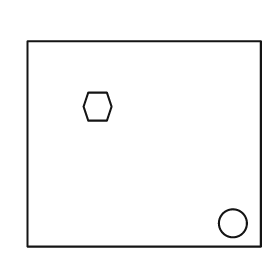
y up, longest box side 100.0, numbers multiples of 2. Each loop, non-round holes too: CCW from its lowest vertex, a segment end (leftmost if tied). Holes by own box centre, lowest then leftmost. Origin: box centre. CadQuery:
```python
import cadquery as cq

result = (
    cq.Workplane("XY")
    .moveTo(-50.0, -44.0)
    .lineTo(50.0, -44.0)
    .lineTo(50.0, 44.0)
    .lineTo(-50.0, 44.0)
    .close()
    .moveTo(38.0, -34.0)
    .circle(6.0)
    .moveTo(-24.0, 10.0)
    .lineTo(-16.0, 10.0)
    .lineTo(-14.0, 16.0)
    .lineTo(-16.0, 22.0)
    .lineTo(-24.0, 22.0)
    .lineTo(-26.0, 16.0)
    .close()
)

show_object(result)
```